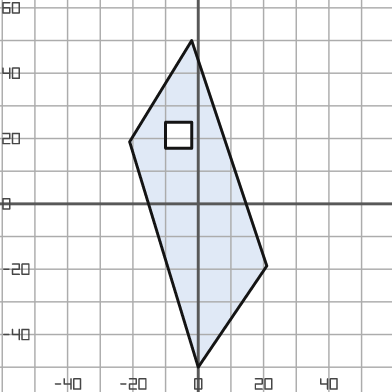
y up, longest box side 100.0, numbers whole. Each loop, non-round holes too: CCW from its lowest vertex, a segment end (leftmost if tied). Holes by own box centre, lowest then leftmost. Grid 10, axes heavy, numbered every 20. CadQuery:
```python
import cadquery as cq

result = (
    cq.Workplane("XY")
    .moveTo(0.0, -50.0)
    .lineTo(21.0, -19.0)
    .lineTo(-2.0, 50.0)
    .lineTo(-21.0, 19.0)
    .close()
    .moveTo(-10.0, 17.0)
    .lineTo(-2.0, 17.0)
    .lineTo(-2.0, 25.0)
    .lineTo(-10.0, 25.0)
    .close()
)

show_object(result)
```